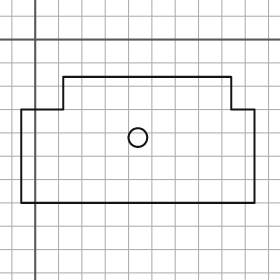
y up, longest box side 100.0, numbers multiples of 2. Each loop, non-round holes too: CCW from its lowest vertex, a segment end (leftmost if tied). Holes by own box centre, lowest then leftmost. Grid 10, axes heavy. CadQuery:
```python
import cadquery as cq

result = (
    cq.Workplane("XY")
    .moveTo(-6.0, -70.0)
    .lineTo(94.0, -70.0)
    .lineTo(94.0, -30.0)
    .lineTo(84.0, -30.0)
    .lineTo(84.0, -16.0)
    .lineTo(12.0, -16.0)
    .lineTo(12.0, -30.0)
    .lineTo(-6.0, -30.0)
    .close()
    .moveTo(44.0, -42.0)
    .circle(4.0)
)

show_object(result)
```